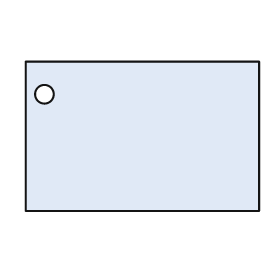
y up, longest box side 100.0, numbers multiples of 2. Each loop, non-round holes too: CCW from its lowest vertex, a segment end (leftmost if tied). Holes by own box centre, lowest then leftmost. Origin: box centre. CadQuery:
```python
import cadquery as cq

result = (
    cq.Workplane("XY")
    .moveTo(-50.0, -32.0)
    .lineTo(50.0, -32.0)
    .lineTo(50.0, 32.0)
    .lineTo(-50.0, 32.0)
    .close()
    .moveTo(-42.0, 18.0)
    .circle(4.0)
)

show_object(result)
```